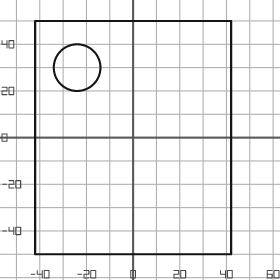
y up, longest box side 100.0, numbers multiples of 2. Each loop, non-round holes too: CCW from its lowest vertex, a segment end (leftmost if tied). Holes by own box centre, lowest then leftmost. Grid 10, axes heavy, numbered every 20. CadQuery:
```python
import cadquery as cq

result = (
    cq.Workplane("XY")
    .moveTo(-42.0, -50.0)
    .lineTo(42.0, -50.0)
    .lineTo(42.0, 50.0)
    .lineTo(-42.0, 50.0)
    .close()
    .moveTo(-24.0, 30.0)
    .circle(10.0)
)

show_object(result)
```